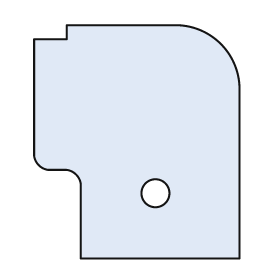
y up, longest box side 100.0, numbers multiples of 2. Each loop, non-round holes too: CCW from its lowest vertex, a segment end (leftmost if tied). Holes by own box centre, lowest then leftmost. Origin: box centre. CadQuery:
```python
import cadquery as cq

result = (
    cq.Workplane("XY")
    .moveTo(-24.0, -50.0)
    .lineTo(44.0, -50.0)
    .lineTo(44.0, 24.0)
    .threePointArc((36.0, 42.0), (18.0, 50.0))
    .lineTo(-30.0, 50.0)
    .lineTo(-30.0, 44.0)
    .lineTo(-44.0, 44.0)
    .lineTo(-44.0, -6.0)
    .threePointArc((-42.0, -10.0), (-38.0, -12.0))
    .lineTo(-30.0, -12.0)
    .threePointArc((-26.0, -14.0), (-24.0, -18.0))
    .close()
    .moveTo(8.0, -22.0)
    .circle(6.0)
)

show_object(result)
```